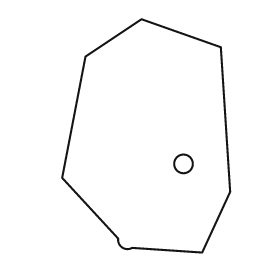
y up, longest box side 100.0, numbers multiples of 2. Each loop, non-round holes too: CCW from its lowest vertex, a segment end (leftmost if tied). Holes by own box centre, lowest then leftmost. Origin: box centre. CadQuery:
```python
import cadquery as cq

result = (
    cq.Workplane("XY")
    .moveTo(24.0, -50.0)
    .lineTo(36.0, -24.0)
    .lineTo(32.0, 38.0)
    .lineTo(-2.0, 50.0)
    .lineTo(-26.0, 34.0)
    .lineTo(-36.0, -18.0)
    .lineTo(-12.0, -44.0)
    .threePointArc((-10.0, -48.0), (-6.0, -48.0))
    .close()
    .moveTo(16.0, -12.0)
    .circle(4.0)
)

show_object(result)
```